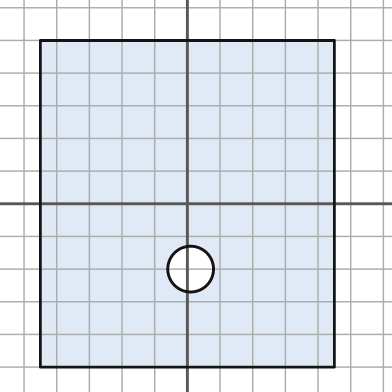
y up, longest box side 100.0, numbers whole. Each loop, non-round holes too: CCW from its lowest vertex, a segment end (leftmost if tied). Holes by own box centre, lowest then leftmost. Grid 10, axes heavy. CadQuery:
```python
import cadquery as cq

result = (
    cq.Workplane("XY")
    .moveTo(-45.0, -50.0)
    .lineTo(45.0, -50.0)
    .lineTo(45.0, 50.0)
    .lineTo(-45.0, 50.0)
    .close()
    .moveTo(1.0, -20.0)
    .circle(7.0)
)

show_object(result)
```